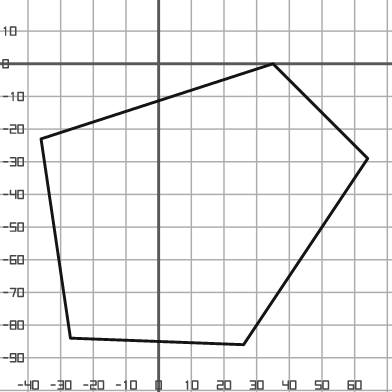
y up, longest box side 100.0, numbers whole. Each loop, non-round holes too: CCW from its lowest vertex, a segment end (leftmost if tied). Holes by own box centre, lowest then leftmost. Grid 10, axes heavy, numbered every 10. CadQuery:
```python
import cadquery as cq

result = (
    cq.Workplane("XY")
    .moveTo(26.0, -86.0)
    .lineTo(64.0, -29.0)
    .lineTo(35.0, 0.0)
    .lineTo(-36.0, -23.0)
    .lineTo(-27.0, -84.0)
    .close()
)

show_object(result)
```